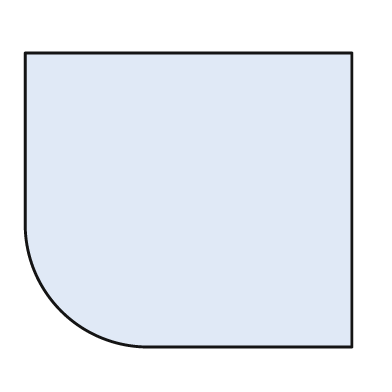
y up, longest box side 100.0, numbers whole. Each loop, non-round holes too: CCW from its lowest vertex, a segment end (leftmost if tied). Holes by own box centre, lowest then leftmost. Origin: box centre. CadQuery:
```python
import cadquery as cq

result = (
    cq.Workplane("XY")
    .moveTo(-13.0, -45.0)
    .lineTo(50.0, -45.0)
    .lineTo(50.0, 45.0)
    .lineTo(-50.0, 45.0)
    .lineTo(-50.0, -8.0)
    .threePointArc((-39.0, -34.0), (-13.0, -45.0))
    .close()
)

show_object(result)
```